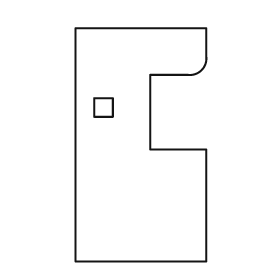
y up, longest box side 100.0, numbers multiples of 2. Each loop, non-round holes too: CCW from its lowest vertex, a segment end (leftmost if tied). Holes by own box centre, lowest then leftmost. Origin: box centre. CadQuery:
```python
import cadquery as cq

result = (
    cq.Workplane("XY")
    .moveTo(-28.0, -50.0)
    .lineTo(28.0, -50.0)
    .lineTo(28.0, -2.0)
    .lineTo(4.0, -2.0)
    .lineTo(4.0, 30.0)
    .lineTo(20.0, 30.0)
    .threePointArc((26.0, 32.0), (28.0, 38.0))
    .lineTo(28.0, 50.0)
    .lineTo(-28.0, 50.0)
    .close()
    .moveTo(-20.0, 12.0)
    .lineTo(-12.0, 12.0)
    .lineTo(-12.0, 20.0)
    .lineTo(-20.0, 20.0)
    .close()
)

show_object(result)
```